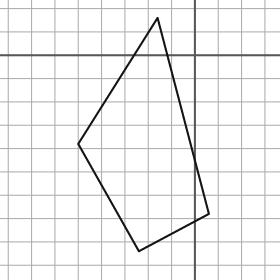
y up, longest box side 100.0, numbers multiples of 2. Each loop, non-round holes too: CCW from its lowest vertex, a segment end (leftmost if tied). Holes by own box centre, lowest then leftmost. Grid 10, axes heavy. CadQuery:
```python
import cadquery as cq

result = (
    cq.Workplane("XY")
    .moveTo(-24.0, -84.0)
    .lineTo(6.0, -68.0)
    .lineTo(-16.0, 16.0)
    .lineTo(-50.0, -38.0)
    .close()
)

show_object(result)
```